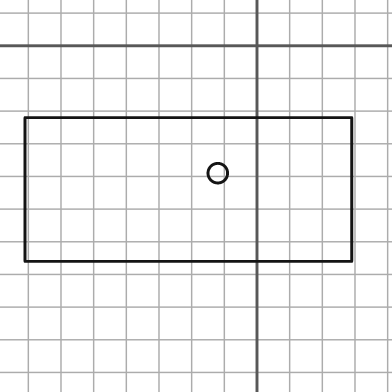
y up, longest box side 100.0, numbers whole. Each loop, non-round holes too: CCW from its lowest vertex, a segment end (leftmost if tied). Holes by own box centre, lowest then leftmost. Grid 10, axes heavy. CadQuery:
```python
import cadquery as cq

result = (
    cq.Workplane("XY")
    .moveTo(-71.0, -66.0)
    .lineTo(29.0, -66.0)
    .lineTo(29.0, -22.0)
    .lineTo(-71.0, -22.0)
    .close()
    .moveTo(-12.0, -39.0)
    .circle(3.0)
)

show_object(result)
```